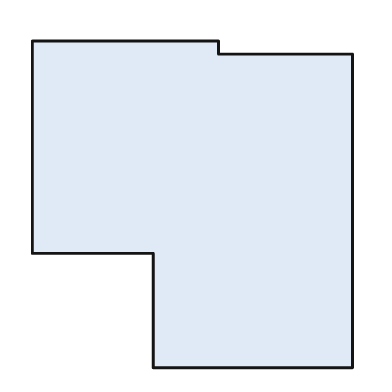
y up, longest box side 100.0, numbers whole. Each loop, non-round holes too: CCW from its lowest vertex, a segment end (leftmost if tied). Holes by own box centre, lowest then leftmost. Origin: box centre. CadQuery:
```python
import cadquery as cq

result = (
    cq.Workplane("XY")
    .moveTo(-12.0, -50.0)
    .lineTo(49.0, -50.0)
    .lineTo(49.0, 46.0)
    .lineTo(8.0, 46.0)
    .lineTo(8.0, 50.0)
    .lineTo(-49.0, 50.0)
    .lineTo(-49.0, -15.0)
    .lineTo(-12.0, -15.0)
    .close()
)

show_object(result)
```